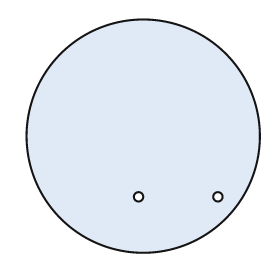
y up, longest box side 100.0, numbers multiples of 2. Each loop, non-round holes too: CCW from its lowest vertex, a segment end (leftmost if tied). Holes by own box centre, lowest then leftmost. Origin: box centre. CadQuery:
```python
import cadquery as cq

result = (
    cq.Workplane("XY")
    .moveTo(0.0, 0.0)
    .circle(50.0)
    .moveTo(-2.0, -26.0)
    .circle(2.0)
    .moveTo(32.0, -26.0)
    .circle(2.0)
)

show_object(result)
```